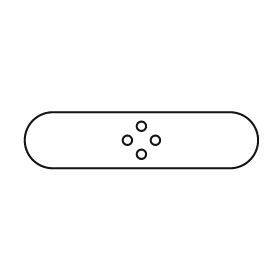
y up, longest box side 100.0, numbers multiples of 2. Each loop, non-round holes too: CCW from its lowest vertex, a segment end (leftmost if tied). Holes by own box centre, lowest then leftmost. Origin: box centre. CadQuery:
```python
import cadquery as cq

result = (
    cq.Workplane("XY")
    .moveTo(-38.0, -12.0)
    .lineTo(38.0, -12.0)
    .threePointArc((50.0, 0.0), (38.0, 12.0))
    .lineTo(-38.0, 12.0)
    .threePointArc((-50.0, 0.0), (-38.0, -12.0))
    .close()
    .moveTo(0.0, -6.0)
    .circle(2.0)
    .moveTo(-6.0, 0.0)
    .circle(2.0)
    .moveTo(6.0, 0.0)
    .circle(2.0)
    .moveTo(0.0, 6.0)
    .circle(2.0)
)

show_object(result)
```